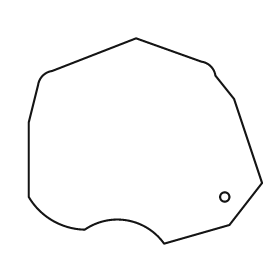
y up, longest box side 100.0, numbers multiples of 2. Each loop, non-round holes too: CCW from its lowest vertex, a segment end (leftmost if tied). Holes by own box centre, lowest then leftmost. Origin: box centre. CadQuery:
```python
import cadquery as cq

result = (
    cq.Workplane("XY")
    .moveTo(8.0, -44.0)
    .lineTo(36.0, -36.0)
    .lineTo(50.0, -18.0)
    .lineTo(38.0, 18.0)
    .lineTo(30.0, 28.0)
    .threePointArc((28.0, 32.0), (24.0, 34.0))
    .lineTo(-4.0, 44.0)
    .lineTo(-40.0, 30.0)
    .threePointArc((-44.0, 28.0), (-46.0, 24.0))
    .lineTo(-50.0, 8.0)
    .lineTo(-50.0, -24.0)
    .threePointArc((-40.0, -34.0), (-26.0, -38.0))
    .threePointArc((-8.0, -34.0), (8.0, -44.0))
    .close()
    .moveTo(34.0, -24.0)
    .circle(2.0)
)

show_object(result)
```